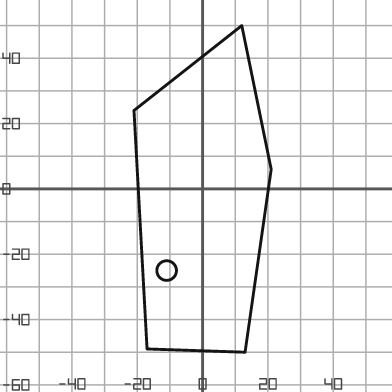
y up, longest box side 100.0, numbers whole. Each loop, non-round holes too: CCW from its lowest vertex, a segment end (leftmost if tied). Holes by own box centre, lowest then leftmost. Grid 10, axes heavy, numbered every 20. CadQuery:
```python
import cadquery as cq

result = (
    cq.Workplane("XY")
    .moveTo(13.0, -50.0)
    .lineTo(21.0, 6.0)
    .lineTo(12.0, 50.0)
    .lineTo(-21.0, 24.0)
    .lineTo(-17.0, -49.0)
    .close()
    .moveTo(-11.0, -25.0)
    .circle(3.0)
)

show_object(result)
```